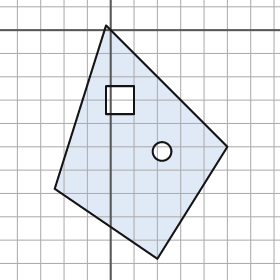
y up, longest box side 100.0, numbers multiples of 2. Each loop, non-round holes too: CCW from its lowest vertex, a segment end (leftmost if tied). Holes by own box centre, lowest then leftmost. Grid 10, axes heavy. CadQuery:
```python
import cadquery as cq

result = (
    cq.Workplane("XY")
    .moveTo(20.0, -98.0)
    .lineTo(50.0, -50.0)
    .lineTo(-2.0, 2.0)
    .lineTo(-24.0, -68.0)
    .close()
    .moveTo(22.0, -52.0)
    .circle(4.0)
    .moveTo(-2.0, -36.0)
    .lineTo(10.0, -36.0)
    .lineTo(10.0, -24.0)
    .lineTo(-2.0, -24.0)
    .close()
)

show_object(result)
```